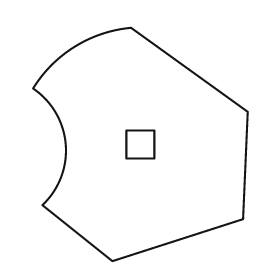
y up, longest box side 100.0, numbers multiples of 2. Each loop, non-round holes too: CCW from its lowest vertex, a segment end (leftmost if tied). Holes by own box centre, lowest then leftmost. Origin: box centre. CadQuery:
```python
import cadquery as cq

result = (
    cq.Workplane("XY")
    .moveTo(-12.0, -50.0)
    .lineTo(44.0, -32.0)
    .lineTo(46.0, 14.0)
    .lineTo(-4.0, 50.0)
    .threePointArc((-28.0, 42.0), (-46.0, 24.0))
    .threePointArc((-32.0, 0.0), (-42.0, -26.0))
    .close()
    .moveTo(-6.0, -6.0)
    .lineTo(6.0, -6.0)
    .lineTo(6.0, 6.0)
    .lineTo(-6.0, 6.0)
    .close()
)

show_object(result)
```